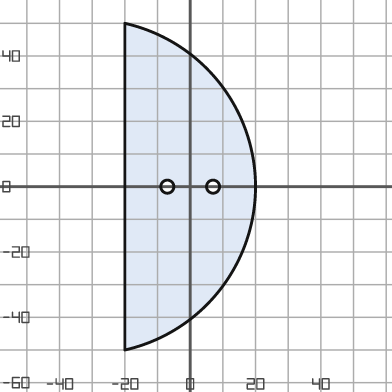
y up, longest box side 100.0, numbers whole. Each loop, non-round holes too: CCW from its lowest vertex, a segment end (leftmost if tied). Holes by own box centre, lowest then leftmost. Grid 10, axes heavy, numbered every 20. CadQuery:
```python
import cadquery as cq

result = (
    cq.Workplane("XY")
    .moveTo(-20.0, -50.0)
    .threePointArc((20.0, 0.0), (-20.0, 50.0))
    .close()
    .moveTo(-7.0, 0.0)
    .circle(2.0)
    .moveTo(7.0, 0.0)
    .circle(2.0)
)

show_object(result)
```